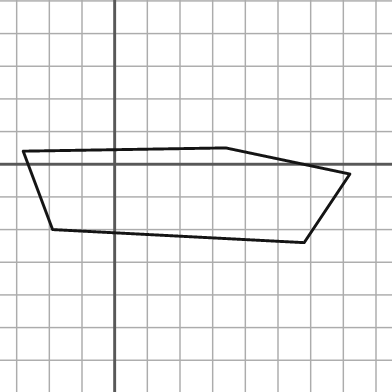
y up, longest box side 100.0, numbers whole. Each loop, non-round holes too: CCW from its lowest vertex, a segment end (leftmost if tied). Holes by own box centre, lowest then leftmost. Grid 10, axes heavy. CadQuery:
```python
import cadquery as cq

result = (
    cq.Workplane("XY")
    .moveTo(58.0, -24.0)
    .lineTo(72.0, -3.0)
    .lineTo(34.0, 5.0)
    .lineTo(-28.0, 4.0)
    .lineTo(-19.0, -20.0)
    .close()
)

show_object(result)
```